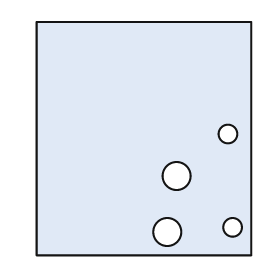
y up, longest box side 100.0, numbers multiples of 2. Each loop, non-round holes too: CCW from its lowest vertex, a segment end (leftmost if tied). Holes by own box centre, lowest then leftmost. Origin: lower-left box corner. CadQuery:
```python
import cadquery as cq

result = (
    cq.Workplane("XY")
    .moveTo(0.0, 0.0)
    .lineTo(92.0, 0.0)
    .lineTo(92.0, 100.0)
    .lineTo(0.0, 100.0)
    .close()
    .moveTo(56.0, 10.0)
    .circle(6.0)
    .moveTo(84.0, 12.0)
    .circle(4.0)
    .moveTo(60.0, 34.0)
    .circle(6.0)
    .moveTo(82.0, 52.0)
    .circle(4.0)
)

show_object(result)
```